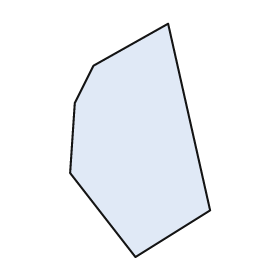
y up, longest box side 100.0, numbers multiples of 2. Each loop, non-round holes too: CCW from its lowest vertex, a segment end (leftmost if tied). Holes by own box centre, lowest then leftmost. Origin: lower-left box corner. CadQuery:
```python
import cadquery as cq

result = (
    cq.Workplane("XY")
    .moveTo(28.0, 0.0)
    .lineTo(60.0, 20.0)
    .lineTo(42.0, 100.0)
    .lineTo(10.0, 82.0)
    .lineTo(2.0, 66.0)
    .lineTo(0.0, 36.0)
    .close()
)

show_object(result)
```